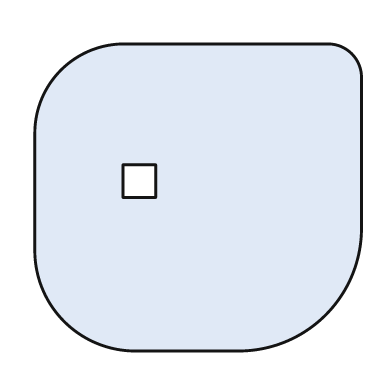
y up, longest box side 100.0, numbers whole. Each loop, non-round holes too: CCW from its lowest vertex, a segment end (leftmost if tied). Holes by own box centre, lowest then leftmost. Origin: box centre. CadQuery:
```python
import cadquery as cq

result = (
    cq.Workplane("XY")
    .moveTo(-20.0, -47.0)
    .lineTo(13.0, -47.0)
    .threePointArc((39.0, -36.0), (50.0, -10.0))
    .lineTo(50.0, 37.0)
    .threePointArc((47.0, 44.0), (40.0, 47.0))
    .lineTo(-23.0, 47.0)
    .threePointArc((-42.0, 39.0), (-50.0, 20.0))
    .lineTo(-50.0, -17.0)
    .threePointArc((-41.0, -38.0), (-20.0, -47.0))
    .close()
    .moveTo(-23.0, 0.0)
    .lineTo(-13.0, 0.0)
    .lineTo(-13.0, 10.0)
    .lineTo(-23.0, 10.0)
    .close()
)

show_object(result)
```